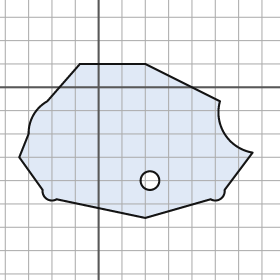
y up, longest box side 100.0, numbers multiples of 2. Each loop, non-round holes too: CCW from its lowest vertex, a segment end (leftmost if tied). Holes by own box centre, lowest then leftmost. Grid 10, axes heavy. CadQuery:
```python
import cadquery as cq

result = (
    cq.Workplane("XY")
    .moveTo(20.0, -56.0)
    .lineTo(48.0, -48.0)
    .threePointArc((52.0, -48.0), (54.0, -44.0))
    .lineTo(66.0, -28.0)
    .threePointArc((54.0, -20.0), (52.0, -6.0))
    .lineTo(20.0, 10.0)
    .lineTo(-8.0, 10.0)
    .lineTo(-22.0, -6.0)
    .threePointArc((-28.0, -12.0), (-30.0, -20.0))
    .lineTo(-34.0, -30.0)
    .lineTo(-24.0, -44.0)
    .threePointArc((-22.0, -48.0), (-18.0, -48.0))
    .close()
    .moveTo(22.0, -40.0)
    .circle(4.0)
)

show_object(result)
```